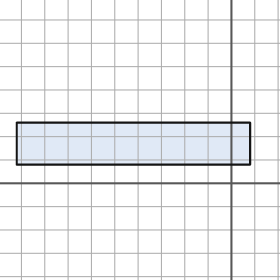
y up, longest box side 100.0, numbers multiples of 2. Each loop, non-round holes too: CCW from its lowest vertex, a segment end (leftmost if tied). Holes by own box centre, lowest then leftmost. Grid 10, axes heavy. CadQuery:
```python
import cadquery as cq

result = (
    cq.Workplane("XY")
    .moveTo(-92.0, 8.0)
    .lineTo(8.0, 8.0)
    .lineTo(8.0, 26.0)
    .lineTo(-92.0, 26.0)
    .close()
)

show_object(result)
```